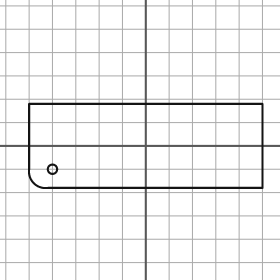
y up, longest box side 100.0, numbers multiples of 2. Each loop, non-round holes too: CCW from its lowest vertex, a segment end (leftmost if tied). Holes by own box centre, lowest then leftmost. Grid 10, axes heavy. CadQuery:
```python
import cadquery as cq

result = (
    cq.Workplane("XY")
    .moveTo(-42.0, -18.0)
    .lineTo(50.0, -18.0)
    .lineTo(50.0, 18.0)
    .lineTo(-50.0, 18.0)
    .lineTo(-50.0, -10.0)
    .threePointArc((-48.0, -16.0), (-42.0, -18.0))
    .close()
    .moveTo(-40.0, -10.0)
    .circle(2.0)
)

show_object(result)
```